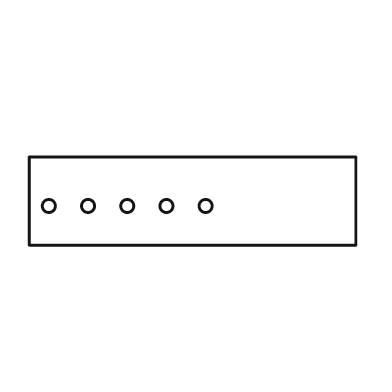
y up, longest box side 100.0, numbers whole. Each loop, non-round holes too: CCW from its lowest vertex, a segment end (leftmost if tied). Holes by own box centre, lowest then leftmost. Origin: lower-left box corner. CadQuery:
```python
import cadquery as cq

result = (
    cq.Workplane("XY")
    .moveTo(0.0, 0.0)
    .lineTo(100.0, 0.0)
    .lineTo(100.0, 27.0)
    .lineTo(0.0, 27.0)
    .close()
    .moveTo(6.0, 12.0)
    .circle(2.0)
    .moveTo(18.0, 12.0)
    .circle(2.0)
    .moveTo(30.0, 12.0)
    .circle(2.0)
    .moveTo(42.0, 12.0)
    .circle(2.0)
    .moveTo(54.0, 12.0)
    .circle(2.0)
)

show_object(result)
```